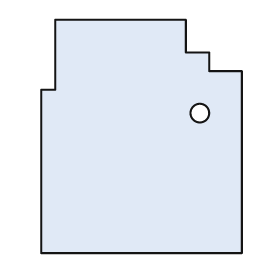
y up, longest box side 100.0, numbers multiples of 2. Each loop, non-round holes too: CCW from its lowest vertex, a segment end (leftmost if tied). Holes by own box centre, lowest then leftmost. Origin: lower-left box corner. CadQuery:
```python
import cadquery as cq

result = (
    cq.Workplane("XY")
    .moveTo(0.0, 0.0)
    .lineTo(86.0, 0.0)
    .lineTo(86.0, 78.0)
    .lineTo(72.0, 78.0)
    .lineTo(72.0, 86.0)
    .lineTo(62.0, 86.0)
    .lineTo(62.0, 100.0)
    .lineTo(6.0, 100.0)
    .lineTo(6.0, 70.0)
    .lineTo(0.0, 70.0)
    .close()
    .moveTo(68.0, 60.0)
    .circle(4.0)
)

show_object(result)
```